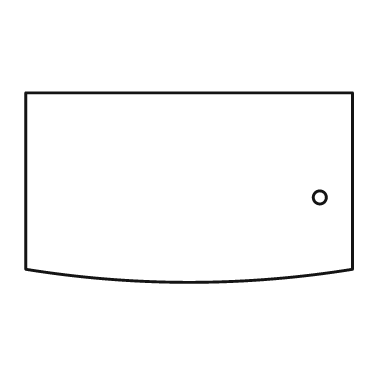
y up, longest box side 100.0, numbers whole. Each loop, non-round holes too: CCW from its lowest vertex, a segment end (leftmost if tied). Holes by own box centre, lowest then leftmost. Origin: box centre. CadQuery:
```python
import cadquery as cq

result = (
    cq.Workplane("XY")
    .moveTo(-50.0, -25.0)
    .threePointArc((0.0, -29.0), (50.0, -25.0))
    .lineTo(50.0, 29.0)
    .lineTo(-50.0, 29.0)
    .close()
    .moveTo(40.0, -3.0)
    .circle(2.0)
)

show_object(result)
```